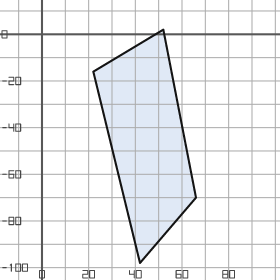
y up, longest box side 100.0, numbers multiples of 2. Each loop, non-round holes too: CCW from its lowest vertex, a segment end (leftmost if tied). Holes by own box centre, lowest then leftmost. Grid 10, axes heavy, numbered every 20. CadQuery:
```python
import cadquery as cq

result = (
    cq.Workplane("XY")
    .moveTo(42.0, -98.0)
    .lineTo(66.0, -70.0)
    .lineTo(52.0, 2.0)
    .lineTo(22.0, -16.0)
    .close()
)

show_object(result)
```